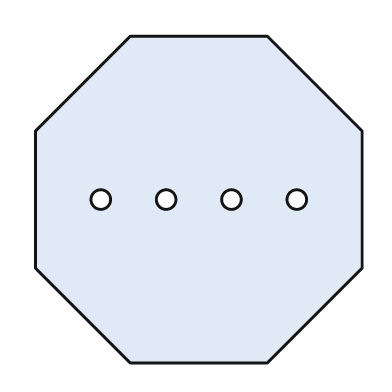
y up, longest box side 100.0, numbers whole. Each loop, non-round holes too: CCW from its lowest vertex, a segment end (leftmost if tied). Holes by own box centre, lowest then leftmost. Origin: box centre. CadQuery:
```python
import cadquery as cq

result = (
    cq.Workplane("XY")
    .moveTo(-21.0, -50.0)
    .lineTo(21.0, -50.0)
    .lineTo(50.0, -21.0)
    .lineTo(50.0, 21.0)
    .lineTo(21.0, 50.0)
    .lineTo(-21.0, 50.0)
    .lineTo(-50.0, 21.0)
    .lineTo(-50.0, -21.0)
    .close()
    .moveTo(-30.0, 0.0)
    .circle(3.0)
    .moveTo(-10.0, 0.0)
    .circle(3.0)
    .moveTo(10.0, 0.0)
    .circle(3.0)
    .moveTo(30.0, 0.0)
    .circle(3.0)
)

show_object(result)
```